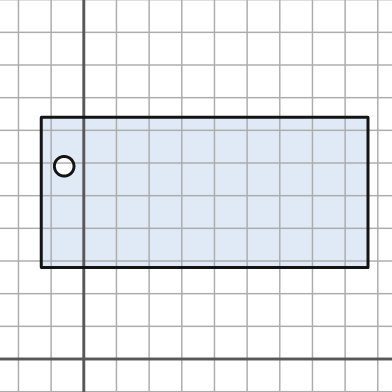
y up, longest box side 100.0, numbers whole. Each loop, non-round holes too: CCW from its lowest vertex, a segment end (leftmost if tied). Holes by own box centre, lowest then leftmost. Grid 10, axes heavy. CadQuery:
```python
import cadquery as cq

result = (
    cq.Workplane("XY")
    .moveTo(-13.0, 28.0)
    .lineTo(87.0, 28.0)
    .lineTo(87.0, 74.0)
    .lineTo(-13.0, 74.0)
    .close()
    .moveTo(-6.0, 59.0)
    .circle(3.0)
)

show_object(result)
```